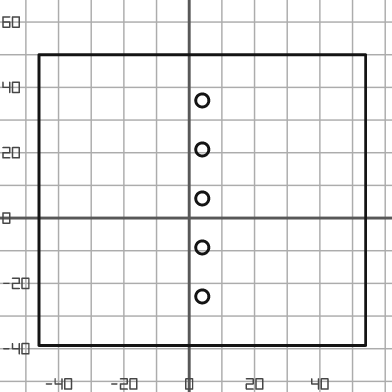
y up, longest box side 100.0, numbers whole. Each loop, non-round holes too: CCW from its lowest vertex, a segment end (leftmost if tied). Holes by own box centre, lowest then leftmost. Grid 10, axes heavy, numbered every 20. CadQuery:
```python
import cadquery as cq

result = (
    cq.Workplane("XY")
    .moveTo(-46.0, -39.0)
    .lineTo(54.0, -39.0)
    .lineTo(54.0, 50.0)
    .lineTo(-46.0, 50.0)
    .close()
    .moveTo(4.0, -24.0)
    .circle(2.0)
    .moveTo(4.0, -9.0)
    .circle(2.0)
    .moveTo(4.0, 6.0)
    .circle(2.0)
    .moveTo(4.0, 21.0)
    .circle(2.0)
    .moveTo(4.0, 36.0)
    .circle(2.0)
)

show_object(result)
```